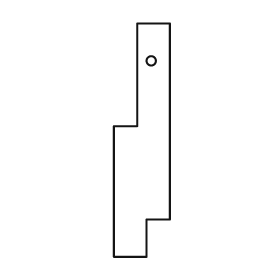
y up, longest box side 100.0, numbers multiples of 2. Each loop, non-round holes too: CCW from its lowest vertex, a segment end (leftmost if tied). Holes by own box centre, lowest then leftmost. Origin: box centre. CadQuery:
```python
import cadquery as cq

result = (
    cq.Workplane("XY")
    .moveTo(-12.0, -50.0)
    .lineTo(2.0, -50.0)
    .lineTo(2.0, -34.0)
    .lineTo(12.0, -34.0)
    .lineTo(12.0, 50.0)
    .lineTo(-2.0, 50.0)
    .lineTo(-2.0, 6.0)
    .lineTo(-12.0, 6.0)
    .close()
    .moveTo(4.0, 34.0)
    .circle(2.0)
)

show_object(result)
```